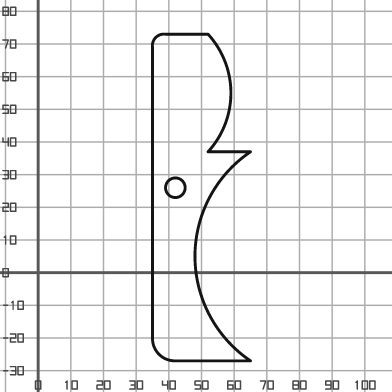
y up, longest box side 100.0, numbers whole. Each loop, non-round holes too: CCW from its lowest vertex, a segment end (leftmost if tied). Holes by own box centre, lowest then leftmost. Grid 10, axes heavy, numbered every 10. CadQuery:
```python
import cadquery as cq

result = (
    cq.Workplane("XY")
    .moveTo(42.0, -27.0)
    .lineTo(65.0, -27.0)
    .threePointArc((48.0, 5.0), (65.0, 37.0))
    .lineTo(52.0, 37.0)
    .threePointArc((59.0, 55.0), (52.0, 73.0))
    .lineTo(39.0, 73.0)
    .threePointArc((36.0, 72.0), (35.0, 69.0))
    .lineTo(35.0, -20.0)
    .threePointArc((37.0, -25.0), (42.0, -27.0))
    .close()
    .moveTo(42.0, 26.0)
    .circle(3.0)
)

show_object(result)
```